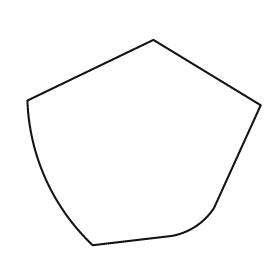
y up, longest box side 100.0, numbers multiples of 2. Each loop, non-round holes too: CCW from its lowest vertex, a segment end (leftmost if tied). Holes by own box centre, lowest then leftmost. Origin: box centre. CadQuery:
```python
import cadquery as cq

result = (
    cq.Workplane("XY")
    .moveTo(-22.0, -44.0)
    .lineTo(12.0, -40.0)
    .threePointArc((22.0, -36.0), (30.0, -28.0))
    .lineTo(50.0, 16.0)
    .lineTo(4.0, 44.0)
    .lineTo(-50.0, 18.0)
    .threePointArc((-42.0, -16.0), (-22.0, -44.0))
    .close()
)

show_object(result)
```